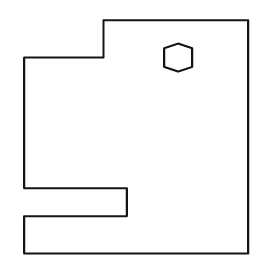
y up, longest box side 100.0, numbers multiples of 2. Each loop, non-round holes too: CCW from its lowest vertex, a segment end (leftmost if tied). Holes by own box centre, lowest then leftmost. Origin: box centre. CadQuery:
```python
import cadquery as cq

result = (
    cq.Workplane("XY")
    .moveTo(-48.0, -50.0)
    .lineTo(48.0, -50.0)
    .lineTo(48.0, 50.0)
    .lineTo(-14.0, 50.0)
    .lineTo(-14.0, 34.0)
    .lineTo(-48.0, 34.0)
    .lineTo(-48.0, -22.0)
    .lineTo(-4.0, -22.0)
    .lineTo(-4.0, -34.0)
    .lineTo(-48.0, -34.0)
    .close()
    .moveTo(18.0, 28.0)
    .lineTo(24.0, 30.0)
    .lineTo(24.0, 38.0)
    .lineTo(18.0, 40.0)
    .lineTo(12.0, 38.0)
    .lineTo(12.0, 30.0)
    .close()
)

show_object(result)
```